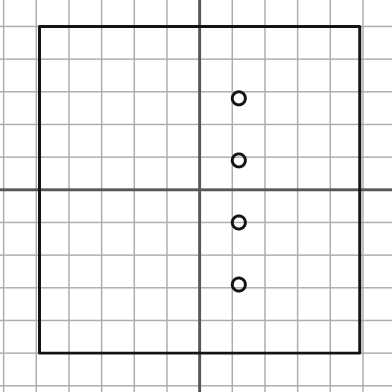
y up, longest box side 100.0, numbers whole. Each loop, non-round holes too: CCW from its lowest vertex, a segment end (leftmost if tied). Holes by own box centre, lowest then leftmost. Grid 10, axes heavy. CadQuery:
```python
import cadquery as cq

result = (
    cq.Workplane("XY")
    .moveTo(-49.0, -50.0)
    .lineTo(49.0, -50.0)
    .lineTo(49.0, 50.0)
    .lineTo(-49.0, 50.0)
    .close()
    .moveTo(12.0, -29.0)
    .circle(2.0)
    .moveTo(12.0, -10.0)
    .circle(2.0)
    .moveTo(12.0, 9.0)
    .circle(2.0)
    .moveTo(12.0, 28.0)
    .circle(2.0)
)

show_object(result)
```